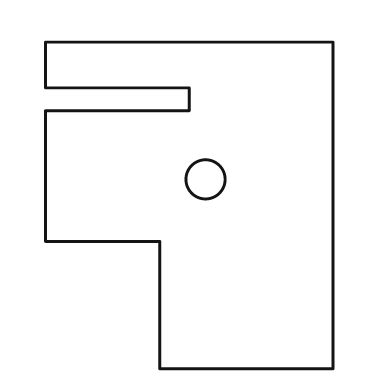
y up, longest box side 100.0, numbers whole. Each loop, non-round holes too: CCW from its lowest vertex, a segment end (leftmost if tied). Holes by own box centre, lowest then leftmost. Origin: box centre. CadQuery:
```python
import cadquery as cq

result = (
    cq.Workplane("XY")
    .moveTo(-9.0, -50.0)
    .lineTo(44.0, -50.0)
    .lineTo(44.0, 50.0)
    .lineTo(-44.0, 50.0)
    .lineTo(-44.0, 36.0)
    .lineTo(0.0, 36.0)
    .lineTo(0.0, 29.0)
    .lineTo(-44.0, 29.0)
    .lineTo(-44.0, -11.0)
    .lineTo(-9.0, -11.0)
    .close()
    .moveTo(5.0, 8.0)
    .circle(6.0)
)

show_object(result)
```